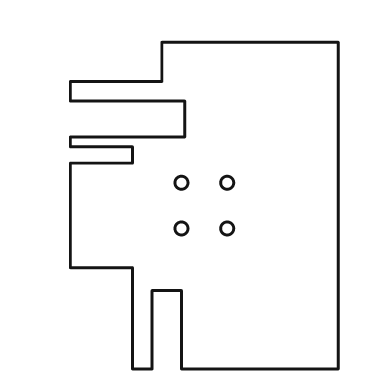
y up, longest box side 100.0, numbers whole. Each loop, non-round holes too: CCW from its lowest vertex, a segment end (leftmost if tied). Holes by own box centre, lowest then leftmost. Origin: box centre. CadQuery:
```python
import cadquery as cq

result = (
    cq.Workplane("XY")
    .moveTo(-22.0, -50.0)
    .lineTo(-16.0, -50.0)
    .lineTo(-16.0, -26.0)
    .lineTo(-7.0, -26.0)
    .lineTo(-7.0, -50.0)
    .lineTo(41.0, -50.0)
    .lineTo(41.0, 50.0)
    .lineTo(-13.0, 50.0)
    .lineTo(-13.0, 38.0)
    .lineTo(-41.0, 38.0)
    .lineTo(-41.0, 32.0)
    .lineTo(-6.0, 32.0)
    .lineTo(-6.0, 21.0)
    .lineTo(-41.0, 21.0)
    .lineTo(-41.0, 18.0)
    .lineTo(-22.0, 18.0)
    .lineTo(-22.0, 13.0)
    .lineTo(-41.0, 13.0)
    .lineTo(-41.0, -19.0)
    .lineTo(-22.0, -19.0)
    .close()
    .moveTo(-7.0, -7.0)
    .circle(2.0)
    .moveTo(7.0, -7.0)
    .circle(2.0)
    .moveTo(-7.0, 7.0)
    .circle(2.0)
    .moveTo(7.0, 7.0)
    .circle(2.0)
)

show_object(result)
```